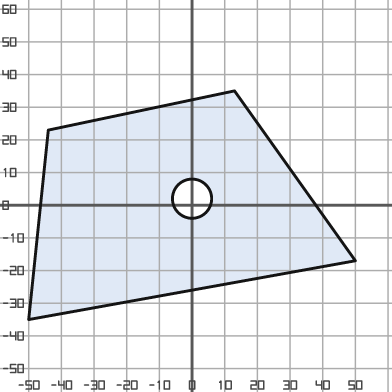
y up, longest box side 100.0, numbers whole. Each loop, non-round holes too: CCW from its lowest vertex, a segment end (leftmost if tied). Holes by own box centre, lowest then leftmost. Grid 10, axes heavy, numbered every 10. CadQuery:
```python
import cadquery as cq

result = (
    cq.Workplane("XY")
    .moveTo(-50.0, -35.0)
    .lineTo(50.0, -17.0)
    .lineTo(13.0, 35.0)
    .lineTo(-44.0, 23.0)
    .close()
    .moveTo(0.0, 2.0)
    .circle(6.0)
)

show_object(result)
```